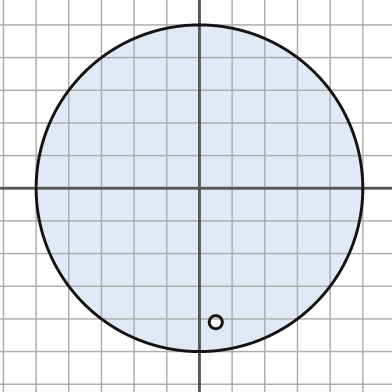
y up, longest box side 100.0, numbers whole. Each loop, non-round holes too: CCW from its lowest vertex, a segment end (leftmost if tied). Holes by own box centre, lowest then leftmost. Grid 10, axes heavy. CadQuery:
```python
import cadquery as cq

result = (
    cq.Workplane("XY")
    .moveTo(0.0, 0.0)
    .circle(50.0)
    .moveTo(5.0, -41.0)
    .circle(2.0)
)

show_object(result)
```